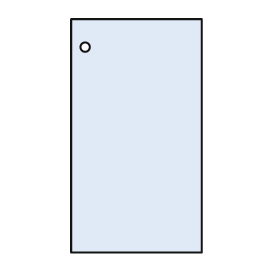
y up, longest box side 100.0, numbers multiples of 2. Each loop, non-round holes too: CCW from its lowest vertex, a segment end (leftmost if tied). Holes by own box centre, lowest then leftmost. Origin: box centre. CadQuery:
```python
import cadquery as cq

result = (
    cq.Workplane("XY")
    .moveTo(-28.0, -50.0)
    .lineTo(28.0, -50.0)
    .lineTo(28.0, 50.0)
    .lineTo(-28.0, 50.0)
    .close()
    .moveTo(-22.0, 38.0)
    .circle(2.0)
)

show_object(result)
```